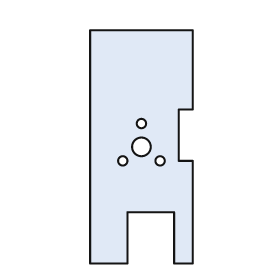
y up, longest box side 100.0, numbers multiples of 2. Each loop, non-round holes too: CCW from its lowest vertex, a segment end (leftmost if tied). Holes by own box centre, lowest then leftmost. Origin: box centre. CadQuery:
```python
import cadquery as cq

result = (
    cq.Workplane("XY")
    .moveTo(-22.0, -50.0)
    .lineTo(-6.0, -50.0)
    .lineTo(-6.0, -28.0)
    .lineTo(14.0, -28.0)
    .lineTo(14.0, -50.0)
    .lineTo(22.0, -50.0)
    .lineTo(22.0, -6.0)
    .lineTo(16.0, -6.0)
    .lineTo(16.0, 16.0)
    .lineTo(22.0, 16.0)
    .lineTo(22.0, 50.0)
    .lineTo(-22.0, 50.0)
    .close()
    .moveTo(-8.0, -6.0)
    .circle(2.0)
    .moveTo(8.0, -6.0)
    .circle(2.0)
    .moveTo(0.0, 0.0)
    .circle(4.0)
    .moveTo(0.0, 10.0)
    .circle(2.0)
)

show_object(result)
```